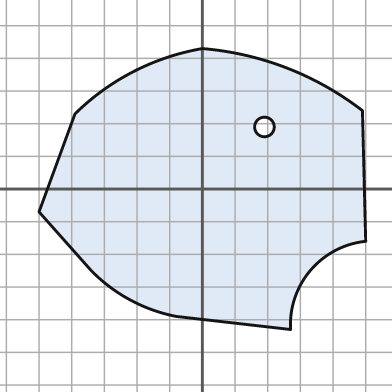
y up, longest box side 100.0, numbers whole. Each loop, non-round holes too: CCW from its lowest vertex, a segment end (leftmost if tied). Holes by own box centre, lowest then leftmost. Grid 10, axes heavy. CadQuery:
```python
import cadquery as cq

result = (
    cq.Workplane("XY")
    .moveTo(27.0, -43.0)
    .threePointArc((33.0, -25.0), (50.0, -16.0))
    .lineTo(49.0, 24.0)
    .threePointArc((26.0, 37.0), (0.0, 43.0))
    .threePointArc((-21.0, 36.0), (-39.0, 23.0))
    .lineTo(-50.0, -7.0)
    .lineTo(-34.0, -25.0)
    .threePointArc((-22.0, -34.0), (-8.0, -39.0))
    .close()
    .moveTo(19.0, 19.0)
    .circle(3.0)
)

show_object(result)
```